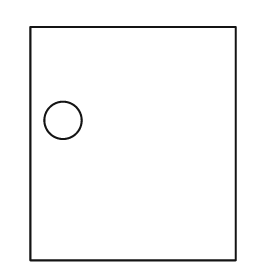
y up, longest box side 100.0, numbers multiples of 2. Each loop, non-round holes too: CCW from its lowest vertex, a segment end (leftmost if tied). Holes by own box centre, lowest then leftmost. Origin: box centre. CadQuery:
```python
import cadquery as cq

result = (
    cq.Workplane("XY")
    .moveTo(-44.0, -50.0)
    .lineTo(44.0, -50.0)
    .lineTo(44.0, 50.0)
    .lineTo(-44.0, 50.0)
    .close()
    .moveTo(-30.0, 10.0)
    .circle(8.0)
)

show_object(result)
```